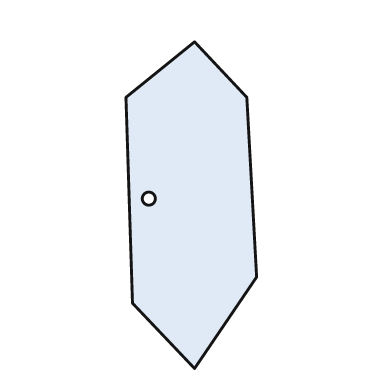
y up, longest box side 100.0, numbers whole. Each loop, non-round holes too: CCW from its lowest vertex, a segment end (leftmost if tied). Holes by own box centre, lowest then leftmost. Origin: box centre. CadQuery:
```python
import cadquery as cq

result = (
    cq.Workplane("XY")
    .moveTo(1.0, -50.0)
    .lineTo(20.0, -22.0)
    .lineTo(17.0, 33.0)
    .lineTo(1.0, 50.0)
    .lineTo(-20.0, 33.0)
    .lineTo(-18.0, -30.0)
    .close()
    .moveTo(-13.0, 2.0)
    .circle(2.0)
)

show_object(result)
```